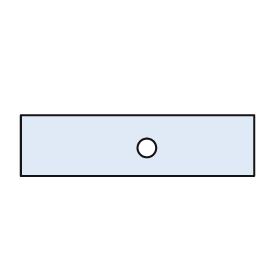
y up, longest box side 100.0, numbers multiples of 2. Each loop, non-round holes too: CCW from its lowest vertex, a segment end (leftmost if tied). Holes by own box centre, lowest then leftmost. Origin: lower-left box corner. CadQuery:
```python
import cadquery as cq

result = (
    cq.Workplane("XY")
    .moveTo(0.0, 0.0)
    .lineTo(100.0, 0.0)
    .lineTo(100.0, 26.0)
    .lineTo(0.0, 26.0)
    .close()
    .moveTo(54.0, 12.0)
    .circle(4.0)
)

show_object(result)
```